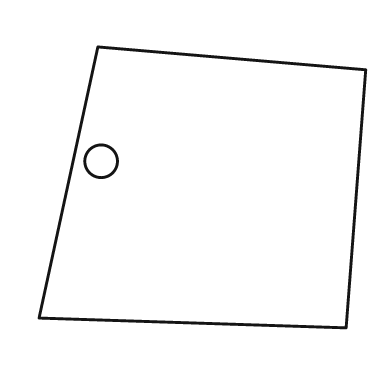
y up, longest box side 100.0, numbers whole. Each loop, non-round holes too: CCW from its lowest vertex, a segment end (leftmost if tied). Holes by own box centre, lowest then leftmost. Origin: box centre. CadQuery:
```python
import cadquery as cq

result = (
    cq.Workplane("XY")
    .moveTo(44.0, -43.0)
    .lineTo(50.0, 36.0)
    .lineTo(-32.0, 43.0)
    .lineTo(-50.0, -40.0)
    .close()
    .moveTo(-31.0, 8.0)
    .circle(5.0)
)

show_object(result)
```